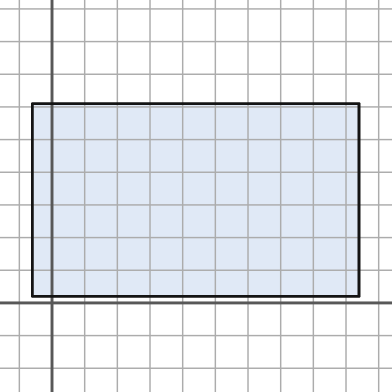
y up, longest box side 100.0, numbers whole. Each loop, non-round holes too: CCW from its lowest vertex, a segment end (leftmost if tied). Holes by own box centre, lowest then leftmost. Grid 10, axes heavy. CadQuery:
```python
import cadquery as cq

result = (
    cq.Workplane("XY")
    .moveTo(-6.0, 2.0)
    .lineTo(94.0, 2.0)
    .lineTo(94.0, 61.0)
    .lineTo(-6.0, 61.0)
    .close()
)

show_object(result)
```